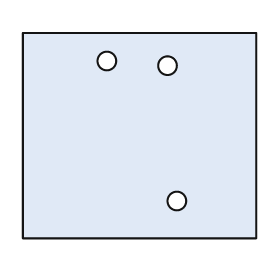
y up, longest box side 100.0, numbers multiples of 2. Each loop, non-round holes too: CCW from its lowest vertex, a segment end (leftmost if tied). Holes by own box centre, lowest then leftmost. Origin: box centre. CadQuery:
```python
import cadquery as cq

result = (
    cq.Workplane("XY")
    .moveTo(-50.0, -44.0)
    .lineTo(50.0, -44.0)
    .lineTo(50.0, 44.0)
    .lineTo(-50.0, 44.0)
    .close()
    .moveTo(16.0, -28.0)
    .circle(4.0)
    .moveTo(12.0, 30.0)
    .circle(4.0)
    .moveTo(-14.0, 32.0)
    .circle(4.0)
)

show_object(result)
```